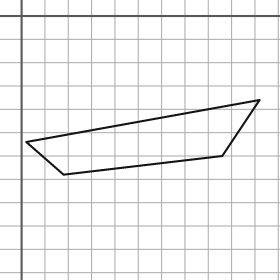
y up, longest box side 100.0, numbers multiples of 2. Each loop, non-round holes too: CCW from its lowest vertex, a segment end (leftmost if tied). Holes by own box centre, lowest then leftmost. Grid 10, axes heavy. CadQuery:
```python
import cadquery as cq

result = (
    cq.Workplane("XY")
    .moveTo(18.0, -68.0)
    .lineTo(86.0, -60.0)
    .lineTo(102.0, -36.0)
    .lineTo(2.0, -54.0)
    .close()
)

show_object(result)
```